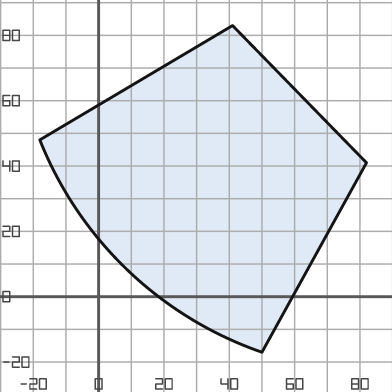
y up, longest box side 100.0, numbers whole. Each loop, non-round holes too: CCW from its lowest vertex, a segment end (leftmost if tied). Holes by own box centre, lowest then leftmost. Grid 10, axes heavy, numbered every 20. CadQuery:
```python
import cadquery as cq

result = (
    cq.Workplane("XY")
    .moveTo(50.0, -17.0)
    .lineTo(82.0, 41.0)
    .lineTo(41.0, 83.0)
    .lineTo(-18.0, 48.0)
    .threePointArc((9.0, 8.0), (50.0, -17.0))
    .close()
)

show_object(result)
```